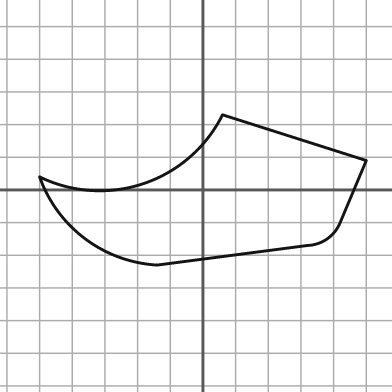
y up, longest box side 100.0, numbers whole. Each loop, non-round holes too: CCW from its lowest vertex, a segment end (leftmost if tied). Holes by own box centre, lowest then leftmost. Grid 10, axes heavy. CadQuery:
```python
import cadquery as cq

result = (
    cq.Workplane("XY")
    .moveTo(-14.0, -23.0)
    .lineTo(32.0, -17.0)
    .threePointArc((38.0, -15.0), (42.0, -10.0))
    .lineTo(50.0, 9.0)
    .lineTo(6.0, 23.0)
    .threePointArc((-18.0, 2.0), (-50.0, 4.0))
    .threePointArc((-36.0, -15.0), (-14.0, -23.0))
    .close()
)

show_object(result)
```